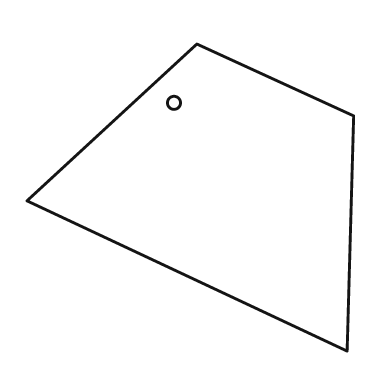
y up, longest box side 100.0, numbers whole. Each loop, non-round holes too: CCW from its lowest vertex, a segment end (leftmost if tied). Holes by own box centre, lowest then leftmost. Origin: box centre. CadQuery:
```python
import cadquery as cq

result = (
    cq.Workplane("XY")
    .moveTo(48.0, -47.0)
    .lineTo(50.0, 25.0)
    .lineTo(2.0, 47.0)
    .lineTo(-50.0, -1.0)
    .close()
    .moveTo(-5.0, 29.0)
    .circle(2.0)
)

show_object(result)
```